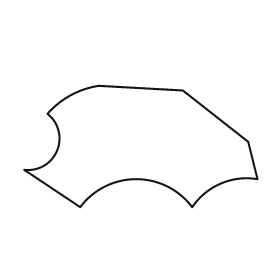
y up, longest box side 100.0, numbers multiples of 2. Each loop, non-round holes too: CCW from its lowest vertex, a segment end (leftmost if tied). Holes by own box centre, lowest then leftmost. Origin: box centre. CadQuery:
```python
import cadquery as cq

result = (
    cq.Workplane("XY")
    .moveTo(-26.0, -26.0)
    .threePointArc((-2.0, -14.0), (22.0, -26.0))
    .threePointArc((34.0, -16.0), (50.0, -14.0))
    .lineTo(46.0, 2.0)
    .lineTo(18.0, 24.0)
    .lineTo(-18.0, 26.0)
    .threePointArc((-30.0, 22.0), (-40.0, 14.0))
    .threePointArc((-36.0, -2.0), (-50.0, -10.0))
    .close()
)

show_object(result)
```